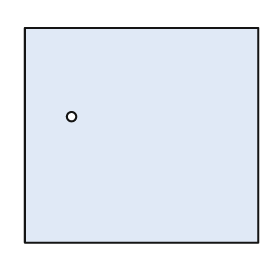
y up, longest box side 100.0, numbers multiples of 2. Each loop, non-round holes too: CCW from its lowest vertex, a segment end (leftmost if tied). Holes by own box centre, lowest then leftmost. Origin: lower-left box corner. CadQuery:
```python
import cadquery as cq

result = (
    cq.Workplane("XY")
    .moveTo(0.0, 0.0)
    .lineTo(100.0, 0.0)
    .lineTo(100.0, 92.0)
    .lineTo(0.0, 92.0)
    .close()
    .moveTo(20.0, 54.0)
    .circle(2.0)
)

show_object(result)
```